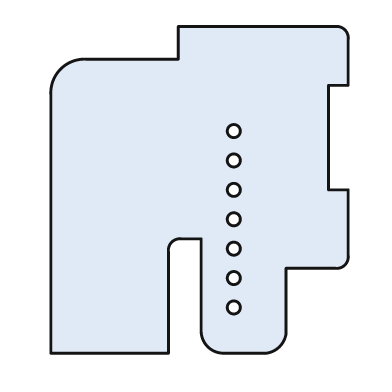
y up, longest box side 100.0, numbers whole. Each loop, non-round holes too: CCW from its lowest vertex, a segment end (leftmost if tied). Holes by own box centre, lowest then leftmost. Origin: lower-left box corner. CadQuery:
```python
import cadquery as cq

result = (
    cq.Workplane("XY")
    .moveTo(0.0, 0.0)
    .lineTo(36.0, 0.0)
    .lineTo(36.0, 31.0)
    .threePointArc((37.0, 34.0), (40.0, 35.0))
    .lineTo(46.0, 35.0)
    .lineTo(46.0, 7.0)
    .threePointArc((48.0, 2.0), (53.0, 0.0))
    .lineTo(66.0, 0.0)
    .threePointArc((70.0, 2.0), (72.0, 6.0))
    .lineTo(72.0, 26.0)
    .lineTo(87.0, 26.0)
    .threePointArc((90.0, 27.0), (91.0, 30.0))
    .lineTo(91.0, 50.0)
    .lineTo(85.0, 50.0)
    .lineTo(85.0, 82.0)
    .lineTo(91.0, 82.0)
    .lineTo(91.0, 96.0)
    .threePointArc((90.0, 99.0), (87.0, 100.0))
    .lineTo(39.0, 100.0)
    .lineTo(39.0, 90.0)
    .lineTo(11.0, 90.0)
    .threePointArc((3.0, 87.0), (0.0, 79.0))
    .close()
    .moveTo(56.0, 14.0)
    .circle(2.0)
    .moveTo(56.0, 23.0)
    .circle(2.0)
    .moveTo(56.0, 32.0)
    .circle(2.0)
    .moveTo(56.0, 41.0)
    .circle(2.0)
    .moveTo(56.0, 50.0)
    .circle(2.0)
    .moveTo(56.0, 59.0)
    .circle(2.0)
    .moveTo(56.0, 68.0)
    .circle(2.0)
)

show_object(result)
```